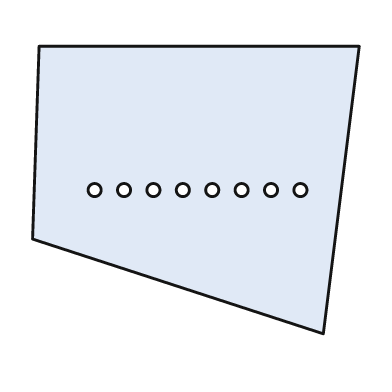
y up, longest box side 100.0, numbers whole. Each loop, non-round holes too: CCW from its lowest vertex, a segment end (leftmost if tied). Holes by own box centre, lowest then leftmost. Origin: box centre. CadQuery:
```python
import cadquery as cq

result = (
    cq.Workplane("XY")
    .moveTo(39.0, -44.0)
    .lineTo(50.0, 44.0)
    .lineTo(-48.0, 44.0)
    .lineTo(-50.0, -15.0)
    .close()
    .moveTo(-31.0, 0.0)
    .circle(2.0)
    .moveTo(-22.0, 0.0)
    .circle(2.0)
    .moveTo(-13.0, 0.0)
    .circle(2.0)
    .moveTo(-4.0, 0.0)
    .circle(2.0)
    .moveTo(5.0, 0.0)
    .circle(2.0)
    .moveTo(14.0, 0.0)
    .circle(2.0)
    .moveTo(23.0, 0.0)
    .circle(2.0)
    .moveTo(32.0, 0.0)
    .circle(2.0)
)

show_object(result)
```